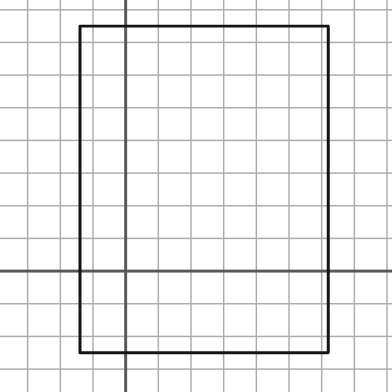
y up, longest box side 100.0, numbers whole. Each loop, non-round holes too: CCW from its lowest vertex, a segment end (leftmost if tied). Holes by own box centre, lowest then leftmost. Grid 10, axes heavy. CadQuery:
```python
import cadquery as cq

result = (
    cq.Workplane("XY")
    .moveTo(-14.0, -25.0)
    .lineTo(62.0, -25.0)
    .lineTo(62.0, 75.0)
    .lineTo(-14.0, 75.0)
    .close()
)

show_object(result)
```